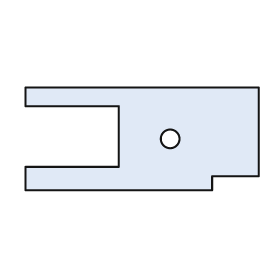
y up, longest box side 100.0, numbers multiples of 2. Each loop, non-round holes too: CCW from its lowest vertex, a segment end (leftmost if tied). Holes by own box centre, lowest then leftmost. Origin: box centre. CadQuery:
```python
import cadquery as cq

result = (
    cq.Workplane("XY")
    .moveTo(-50.0, -22.0)
    .lineTo(30.0, -22.0)
    .lineTo(30.0, -16.0)
    .lineTo(50.0, -16.0)
    .lineTo(50.0, 22.0)
    .lineTo(-50.0, 22.0)
    .lineTo(-50.0, 14.0)
    .lineTo(-10.0, 14.0)
    .lineTo(-10.0, -12.0)
    .lineTo(-50.0, -12.0)
    .close()
    .moveTo(12.0, 0.0)
    .circle(4.0)
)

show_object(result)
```